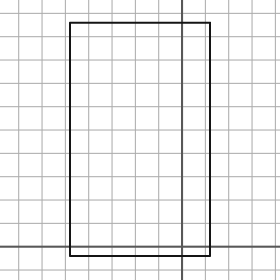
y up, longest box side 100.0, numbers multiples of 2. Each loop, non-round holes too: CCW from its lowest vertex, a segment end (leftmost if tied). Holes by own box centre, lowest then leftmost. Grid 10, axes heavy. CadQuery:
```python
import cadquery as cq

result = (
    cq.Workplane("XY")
    .moveTo(-48.0, -4.0)
    .lineTo(12.0, -4.0)
    .lineTo(12.0, 96.0)
    .lineTo(-48.0, 96.0)
    .close()
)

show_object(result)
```